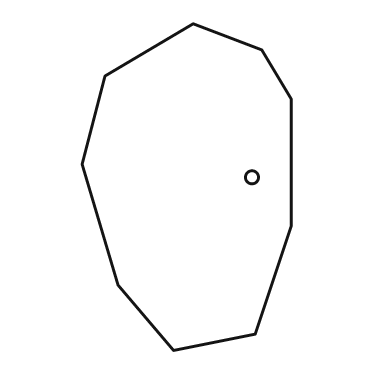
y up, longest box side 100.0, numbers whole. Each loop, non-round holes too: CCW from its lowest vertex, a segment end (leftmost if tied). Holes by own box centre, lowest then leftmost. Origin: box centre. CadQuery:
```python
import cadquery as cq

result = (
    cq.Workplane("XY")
    .moveTo(-4.0, -50.0)
    .lineTo(21.0, -45.0)
    .lineTo(32.0, -12.0)
    .lineTo(32.0, 27.0)
    .lineTo(23.0, 42.0)
    .lineTo(2.0, 50.0)
    .lineTo(-25.0, 34.0)
    .lineTo(-32.0, 7.0)
    .lineTo(-21.0, -30.0)
    .close()
    .moveTo(20.0, 3.0)
    .circle(2.0)
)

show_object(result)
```